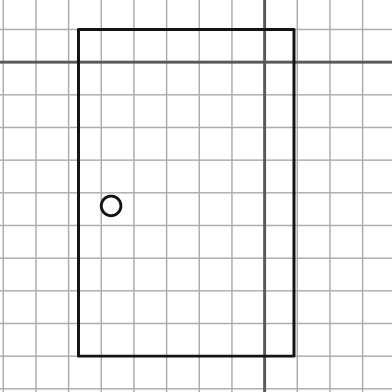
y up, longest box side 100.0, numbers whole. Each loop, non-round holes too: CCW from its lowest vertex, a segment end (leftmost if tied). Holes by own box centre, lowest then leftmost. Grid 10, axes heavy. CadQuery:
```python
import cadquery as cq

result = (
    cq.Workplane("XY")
    .moveTo(-57.0, -90.0)
    .lineTo(9.0, -90.0)
    .lineTo(9.0, 10.0)
    .lineTo(-57.0, 10.0)
    .close()
    .moveTo(-47.0, -44.0)
    .circle(3.0)
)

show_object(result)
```